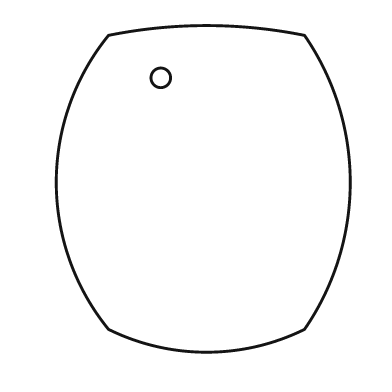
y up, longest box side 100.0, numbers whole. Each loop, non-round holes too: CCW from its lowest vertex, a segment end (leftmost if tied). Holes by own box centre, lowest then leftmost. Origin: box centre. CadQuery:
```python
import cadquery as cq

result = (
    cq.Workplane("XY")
    .moveTo(-29.0, -43.0)
    .threePointArc((1.0, -50.0), (31.0, -43.0))
    .threePointArc((45.0, 2.0), (31.0, 47.0))
    .threePointArc((1.0, 50.0), (-29.0, 47.0))
    .threePointArc((-45.0, 2.0), (-29.0, -43.0))
    .close()
    .moveTo(-13.0, 34.0)
    .circle(3.0)
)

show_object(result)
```